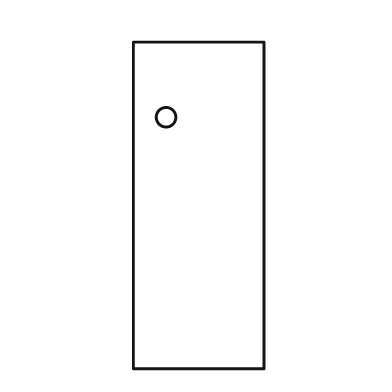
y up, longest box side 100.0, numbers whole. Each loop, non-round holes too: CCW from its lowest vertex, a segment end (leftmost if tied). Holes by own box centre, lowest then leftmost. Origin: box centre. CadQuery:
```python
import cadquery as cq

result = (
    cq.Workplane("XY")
    .moveTo(-20.0, -50.0)
    .lineTo(20.0, -50.0)
    .lineTo(20.0, 50.0)
    .lineTo(-20.0, 50.0)
    .close()
    .moveTo(-10.0, 27.0)
    .circle(3.0)
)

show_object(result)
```